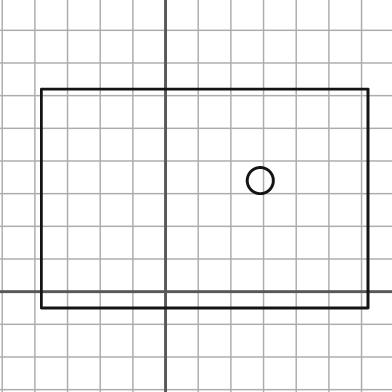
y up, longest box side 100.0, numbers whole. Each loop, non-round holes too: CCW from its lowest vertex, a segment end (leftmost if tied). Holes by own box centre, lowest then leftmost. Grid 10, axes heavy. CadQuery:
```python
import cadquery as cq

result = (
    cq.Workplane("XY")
    .moveTo(-38.0, -5.0)
    .lineTo(62.0, -5.0)
    .lineTo(62.0, 62.0)
    .lineTo(-38.0, 62.0)
    .close()
    .moveTo(29.0, 34.0)
    .circle(4.0)
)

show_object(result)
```